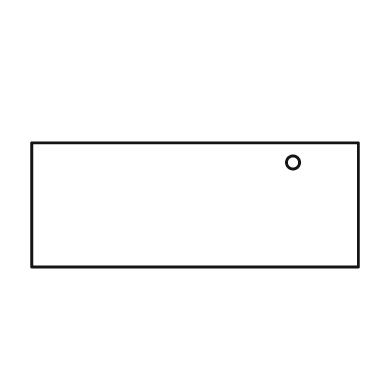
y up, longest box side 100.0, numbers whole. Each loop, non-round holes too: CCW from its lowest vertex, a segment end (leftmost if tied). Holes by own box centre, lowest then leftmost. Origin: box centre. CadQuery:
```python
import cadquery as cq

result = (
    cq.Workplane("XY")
    .moveTo(-50.0, -19.0)
    .lineTo(50.0, -19.0)
    .lineTo(50.0, 19.0)
    .lineTo(-50.0, 19.0)
    .close()
    .moveTo(30.0, 13.0)
    .circle(2.0)
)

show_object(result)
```